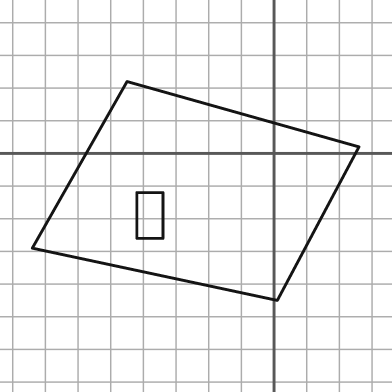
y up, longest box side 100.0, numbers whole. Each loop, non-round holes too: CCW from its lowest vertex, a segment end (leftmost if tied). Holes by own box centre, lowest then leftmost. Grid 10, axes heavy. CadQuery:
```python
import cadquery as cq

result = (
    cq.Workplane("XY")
    .moveTo(1.0, -45.0)
    .lineTo(26.0, 2.0)
    .lineTo(-45.0, 22.0)
    .lineTo(-74.0, -29.0)
    .close()
    .moveTo(-42.0, -26.0)
    .lineTo(-34.0, -26.0)
    .lineTo(-34.0, -12.0)
    .lineTo(-42.0, -12.0)
    .close()
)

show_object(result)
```